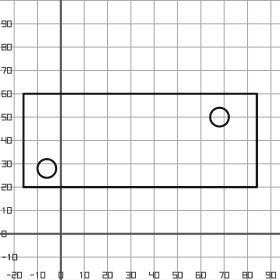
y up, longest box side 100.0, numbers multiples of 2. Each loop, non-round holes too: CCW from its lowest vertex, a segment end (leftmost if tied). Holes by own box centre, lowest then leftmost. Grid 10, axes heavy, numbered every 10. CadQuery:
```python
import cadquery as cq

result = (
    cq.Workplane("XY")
    .moveTo(-16.0, 20.0)
    .lineTo(84.0, 20.0)
    .lineTo(84.0, 60.0)
    .lineTo(-16.0, 60.0)
    .close()
    .moveTo(-6.0, 28.0)
    .circle(4.0)
    .moveTo(68.0, 50.0)
    .circle(4.0)
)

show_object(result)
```